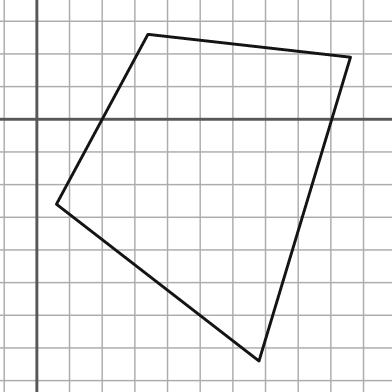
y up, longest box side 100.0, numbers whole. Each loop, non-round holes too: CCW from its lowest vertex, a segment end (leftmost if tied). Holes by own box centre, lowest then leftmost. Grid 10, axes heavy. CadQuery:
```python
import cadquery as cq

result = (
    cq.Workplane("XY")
    .moveTo(68.0, -74.0)
    .lineTo(96.0, 19.0)
    .lineTo(34.0, 26.0)
    .lineTo(6.0, -26.0)
    .close()
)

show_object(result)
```